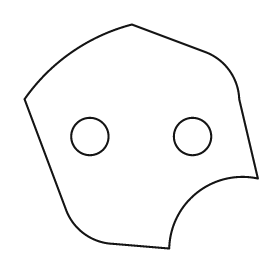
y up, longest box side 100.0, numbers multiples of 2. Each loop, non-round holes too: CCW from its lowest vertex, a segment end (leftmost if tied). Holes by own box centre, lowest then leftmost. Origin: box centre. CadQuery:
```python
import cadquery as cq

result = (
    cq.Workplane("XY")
    .moveTo(12.0, -48.0)
    .threePointArc((24.0, -24.0), (50.0, -18.0))
    .lineTo(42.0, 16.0)
    .threePointArc((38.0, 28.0), (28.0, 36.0))
    .lineTo(-4.0, 48.0)
    .threePointArc((-30.0, 36.0), (-50.0, 16.0))
    .lineTo(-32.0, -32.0)
    .threePointArc((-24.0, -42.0), (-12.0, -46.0))
    .close()
    .moveTo(-22.0, 0.0)
    .circle(8.0)
    .moveTo(22.0, 0.0)
    .circle(8.0)
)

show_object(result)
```